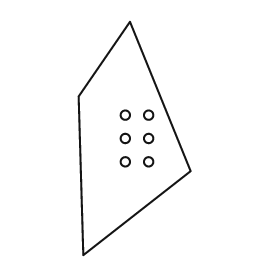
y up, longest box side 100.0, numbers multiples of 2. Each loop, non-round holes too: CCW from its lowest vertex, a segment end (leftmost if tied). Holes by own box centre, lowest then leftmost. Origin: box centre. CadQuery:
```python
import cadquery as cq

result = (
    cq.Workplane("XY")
    .moveTo(-22.0, -50.0)
    .lineTo(24.0, -14.0)
    .lineTo(-2.0, 50.0)
    .lineTo(-24.0, 18.0)
    .close()
    .moveTo(-4.0, -10.0)
    .circle(2.0)
    .moveTo(6.0, -10.0)
    .circle(2.0)
    .moveTo(-4.0, 0.0)
    .circle(2.0)
    .moveTo(6.0, 0.0)
    .circle(2.0)
    .moveTo(-4.0, 10.0)
    .circle(2.0)
    .moveTo(6.0, 10.0)
    .circle(2.0)
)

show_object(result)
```